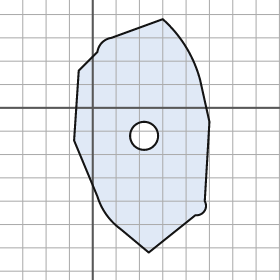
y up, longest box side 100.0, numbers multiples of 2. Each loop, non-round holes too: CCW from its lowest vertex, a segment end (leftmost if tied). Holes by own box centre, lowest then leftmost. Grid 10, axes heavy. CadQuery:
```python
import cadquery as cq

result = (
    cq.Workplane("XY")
    .moveTo(24.0, -62.0)
    .lineTo(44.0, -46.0)
    .threePointArc((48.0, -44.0), (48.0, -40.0))
    .lineTo(50.0, -6.0)
    .lineTo(46.0, 12.0)
    .threePointArc((40.0, 26.0), (30.0, 38.0))
    .lineTo(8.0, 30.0)
    .threePointArc((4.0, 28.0), (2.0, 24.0))
    .lineTo(-6.0, 16.0)
    .lineTo(-8.0, -14.0)
    .lineTo(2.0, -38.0)
    .threePointArc((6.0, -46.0), (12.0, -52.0))
    .close()
    .moveTo(22.0, -12.0)
    .circle(6.0)
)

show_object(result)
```